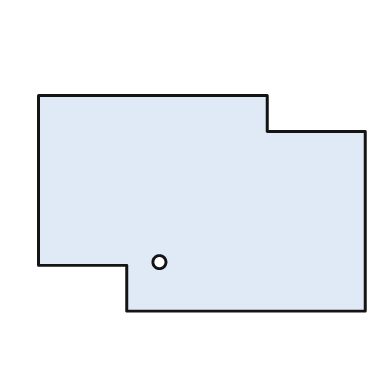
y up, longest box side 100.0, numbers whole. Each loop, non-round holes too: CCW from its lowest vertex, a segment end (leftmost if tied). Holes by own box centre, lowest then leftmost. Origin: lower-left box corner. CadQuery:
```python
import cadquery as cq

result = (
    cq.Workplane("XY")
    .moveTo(27.0, 0.0)
    .lineTo(100.0, 0.0)
    .lineTo(100.0, 55.0)
    .lineTo(70.0, 55.0)
    .lineTo(70.0, 66.0)
    .lineTo(0.0, 66.0)
    .lineTo(0.0, 14.0)
    .lineTo(27.0, 14.0)
    .close()
    .moveTo(37.0, 15.0)
    .circle(2.0)
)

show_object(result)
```